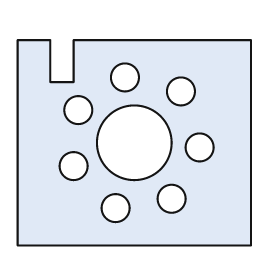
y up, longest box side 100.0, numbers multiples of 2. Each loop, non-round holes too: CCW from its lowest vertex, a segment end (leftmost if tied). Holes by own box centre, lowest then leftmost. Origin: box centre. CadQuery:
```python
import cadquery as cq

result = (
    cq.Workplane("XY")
    .moveTo(-50.0, -44.0)
    .lineTo(50.0, -44.0)
    .lineTo(50.0, 44.0)
    .lineTo(-26.0, 44.0)
    .lineTo(-26.0, 26.0)
    .lineTo(-36.0, 26.0)
    .lineTo(-36.0, 44.0)
    .lineTo(-50.0, 44.0)
    .close()
    .moveTo(-8.0, -28.0)
    .circle(6.0)
    .moveTo(16.0, -24.0)
    .circle(6.0)
    .moveTo(-26.0, -10.0)
    .circle(6.0)
    .moveTo(28.0, -2.0)
    .circle(6.0)
    .moveTo(0.0, 0.0)
    .circle(16.0)
    .moveTo(-24.0, 14.0)
    .circle(6.0)
    .moveTo(20.0, 22.0)
    .circle(6.0)
    .moveTo(-4.0, 28.0)
    .circle(6.0)
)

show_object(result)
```